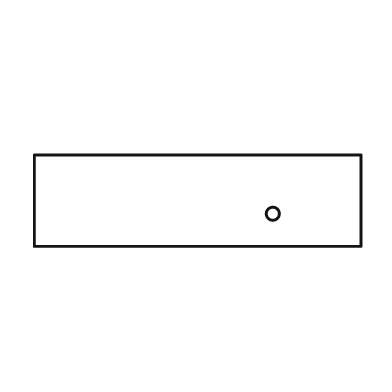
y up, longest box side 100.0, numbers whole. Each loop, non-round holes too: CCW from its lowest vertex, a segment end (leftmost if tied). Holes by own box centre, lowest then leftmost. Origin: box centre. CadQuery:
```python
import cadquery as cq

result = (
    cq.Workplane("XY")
    .moveTo(-50.0, -14.0)
    .lineTo(50.0, -14.0)
    .lineTo(50.0, 14.0)
    .lineTo(-50.0, 14.0)
    .close()
    .moveTo(23.0, -4.0)
    .circle(2.0)
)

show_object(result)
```